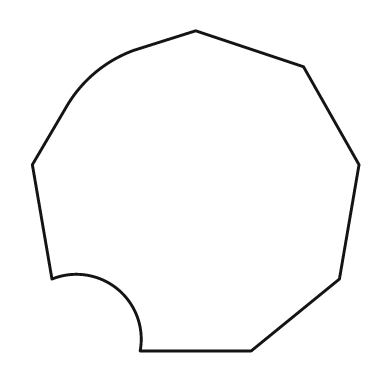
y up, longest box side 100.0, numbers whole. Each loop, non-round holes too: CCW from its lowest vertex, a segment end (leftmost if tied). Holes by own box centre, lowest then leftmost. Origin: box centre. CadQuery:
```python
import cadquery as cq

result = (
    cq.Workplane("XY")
    .moveTo(-17.0, -49.0)
    .lineTo(17.0, -49.0)
    .lineTo(44.0, -27.0)
    .lineTo(50.0, 8.0)
    .lineTo(33.0, 38.0)
    .lineTo(0.0, 49.0)
    .lineTo(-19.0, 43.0)
    .threePointArc((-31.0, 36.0), (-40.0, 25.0))
    .lineTo(-50.0, 8.0)
    .lineTo(-44.0, -27.0)
    .threePointArc((-24.0, -30.0), (-17.0, -49.0))
    .close()
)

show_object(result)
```